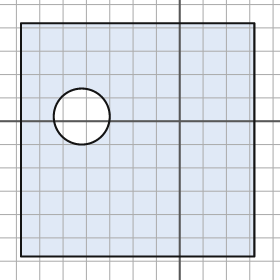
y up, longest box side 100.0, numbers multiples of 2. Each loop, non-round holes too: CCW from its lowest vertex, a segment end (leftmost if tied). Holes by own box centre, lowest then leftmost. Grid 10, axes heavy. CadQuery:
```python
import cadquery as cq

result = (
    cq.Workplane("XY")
    .moveTo(-68.0, -58.0)
    .lineTo(32.0, -58.0)
    .lineTo(32.0, 42.0)
    .lineTo(-68.0, 42.0)
    .close()
    .moveTo(-42.0, 2.0)
    .circle(12.0)
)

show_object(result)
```